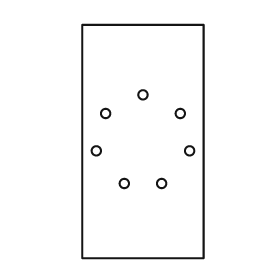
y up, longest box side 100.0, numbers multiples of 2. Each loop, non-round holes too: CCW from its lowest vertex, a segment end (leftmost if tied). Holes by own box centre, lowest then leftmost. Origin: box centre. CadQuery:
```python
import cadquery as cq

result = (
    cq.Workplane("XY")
    .moveTo(-26.0, -50.0)
    .lineTo(26.0, -50.0)
    .lineTo(26.0, 50.0)
    .lineTo(-26.0, 50.0)
    .close()
    .moveTo(-8.0, -18.0)
    .circle(2.0)
    .moveTo(8.0, -18.0)
    .circle(2.0)
    .moveTo(-20.0, -4.0)
    .circle(2.0)
    .moveTo(20.0, -4.0)
    .circle(2.0)
    .moveTo(-16.0, 12.0)
    .circle(2.0)
    .moveTo(16.0, 12.0)
    .circle(2.0)
    .moveTo(0.0, 20.0)
    .circle(2.0)
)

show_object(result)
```